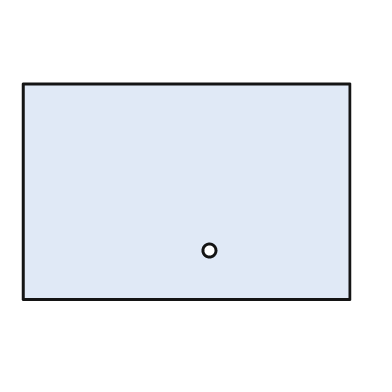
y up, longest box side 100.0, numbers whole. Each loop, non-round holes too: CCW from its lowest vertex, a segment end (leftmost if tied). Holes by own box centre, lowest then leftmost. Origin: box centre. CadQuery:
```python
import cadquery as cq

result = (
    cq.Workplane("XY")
    .moveTo(-50.0, -33.0)
    .lineTo(50.0, -33.0)
    .lineTo(50.0, 33.0)
    .lineTo(-50.0, 33.0)
    .close()
    .moveTo(7.0, -18.0)
    .circle(2.0)
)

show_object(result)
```